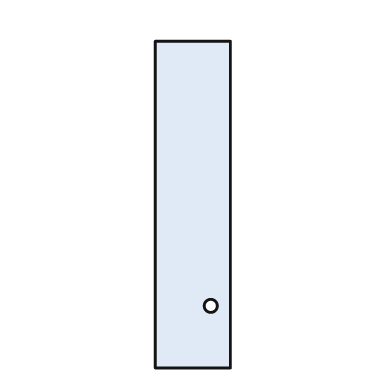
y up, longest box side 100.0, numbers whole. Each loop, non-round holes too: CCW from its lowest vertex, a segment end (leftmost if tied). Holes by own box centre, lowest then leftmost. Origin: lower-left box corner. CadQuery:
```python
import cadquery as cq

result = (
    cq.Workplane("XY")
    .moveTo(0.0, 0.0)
    .lineTo(23.0, 0.0)
    .lineTo(23.0, 100.0)
    .lineTo(0.0, 100.0)
    .close()
    .moveTo(17.0, 19.0)
    .circle(2.0)
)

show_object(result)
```